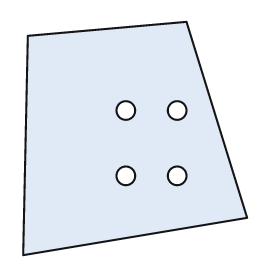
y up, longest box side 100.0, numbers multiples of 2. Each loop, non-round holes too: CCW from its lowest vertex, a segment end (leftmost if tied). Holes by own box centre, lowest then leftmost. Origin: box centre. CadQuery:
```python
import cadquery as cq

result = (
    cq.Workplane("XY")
    .moveTo(-48.0, -50.0)
    .lineTo(48.0, -34.0)
    .lineTo(22.0, 50.0)
    .lineTo(-46.0, 44.0)
    .close()
    .moveTo(-4.0, -16.0)
    .circle(4.0)
    .moveTo(18.0, -16.0)
    .circle(4.0)
    .moveTo(-4.0, 12.0)
    .circle(4.0)
    .moveTo(18.0, 12.0)
    .circle(4.0)
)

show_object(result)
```